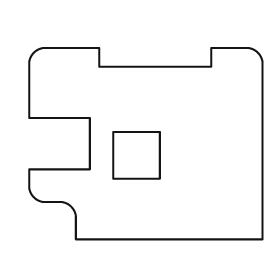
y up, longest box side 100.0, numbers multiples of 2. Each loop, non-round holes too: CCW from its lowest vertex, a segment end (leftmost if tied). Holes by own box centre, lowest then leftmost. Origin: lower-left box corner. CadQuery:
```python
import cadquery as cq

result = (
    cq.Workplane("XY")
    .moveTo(20.0, 0.0)
    .lineTo(100.0, 0.0)
    .lineTo(100.0, 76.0)
    .threePointArc((98.0, 80.0), (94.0, 82.0))
    .lineTo(78.0, 82.0)
    .lineTo(78.0, 74.0)
    .lineTo(30.0, 74.0)
    .lineTo(30.0, 82.0)
    .lineTo(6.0, 82.0)
    .threePointArc((2.0, 80.0), (0.0, 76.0))
    .lineTo(0.0, 52.0)
    .lineTo(26.0, 52.0)
    .lineTo(26.0, 30.0)
    .lineTo(0.0, 30.0)
    .lineTo(0.0, 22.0)
    .threePointArc((2.0, 18.0), (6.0, 16.0))
    .lineTo(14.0, 16.0)
    .threePointArc((18.0, 14.0), (20.0, 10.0))
    .close()
    .moveTo(36.0, 26.0)
    .lineTo(56.0, 26.0)
    .lineTo(56.0, 46.0)
    .lineTo(36.0, 46.0)
    .close()
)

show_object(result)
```